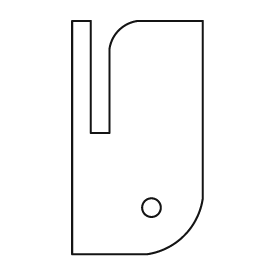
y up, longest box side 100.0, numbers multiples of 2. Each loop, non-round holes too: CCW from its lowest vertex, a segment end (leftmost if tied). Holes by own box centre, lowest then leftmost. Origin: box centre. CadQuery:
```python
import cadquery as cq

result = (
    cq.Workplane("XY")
    .moveTo(-28.0, -50.0)
    .lineTo(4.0, -50.0)
    .threePointArc((20.0, -42.0), (28.0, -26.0))
    .lineTo(28.0, 50.0)
    .lineTo(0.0, 50.0)
    .threePointArc((-8.0, 46.0), (-12.0, 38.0))
    .lineTo(-12.0, 2.0)
    .lineTo(-20.0, 2.0)
    .lineTo(-20.0, 50.0)
    .lineTo(-28.0, 50.0)
    .close()
    .moveTo(6.0, -30.0)
    .circle(4.0)
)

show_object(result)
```